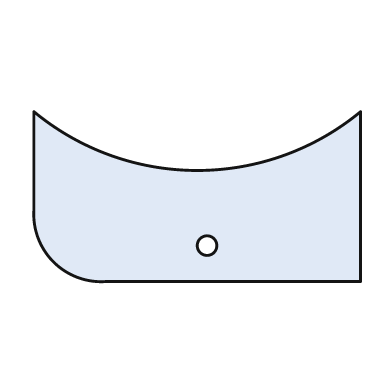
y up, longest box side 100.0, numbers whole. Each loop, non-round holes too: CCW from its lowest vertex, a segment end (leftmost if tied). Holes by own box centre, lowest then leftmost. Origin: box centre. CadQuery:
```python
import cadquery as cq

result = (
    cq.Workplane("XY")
    .moveTo(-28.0, -26.0)
    .lineTo(50.0, -26.0)
    .lineTo(50.0, 26.0)
    .threePointArc((0.0, 8.0), (-50.0, 26.0))
    .lineTo(-50.0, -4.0)
    .threePointArc((-44.0, -20.0), (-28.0, -26.0))
    .close()
    .moveTo(3.0, -15.0)
    .circle(3.0)
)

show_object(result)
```